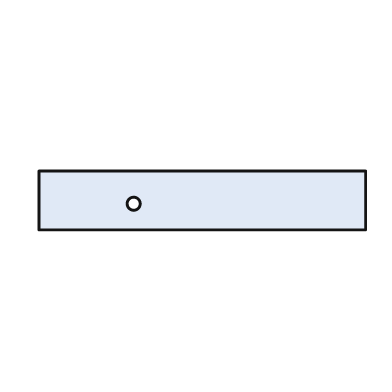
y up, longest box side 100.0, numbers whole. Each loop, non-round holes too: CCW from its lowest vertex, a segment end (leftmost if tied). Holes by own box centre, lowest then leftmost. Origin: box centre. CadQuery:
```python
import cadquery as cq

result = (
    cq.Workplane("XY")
    .moveTo(-50.0, -9.0)
    .lineTo(50.0, -9.0)
    .lineTo(50.0, 9.0)
    .lineTo(-50.0, 9.0)
    .close()
    .moveTo(-21.0, -1.0)
    .circle(2.0)
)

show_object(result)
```